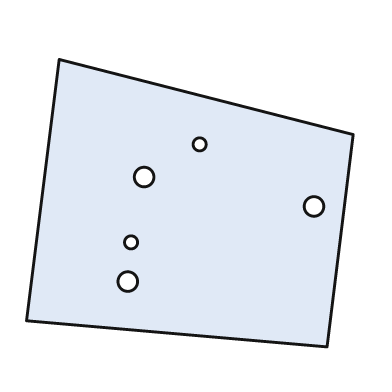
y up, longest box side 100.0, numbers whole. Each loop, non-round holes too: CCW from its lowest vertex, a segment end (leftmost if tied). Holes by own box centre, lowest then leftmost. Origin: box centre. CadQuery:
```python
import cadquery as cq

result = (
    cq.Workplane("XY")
    .moveTo(42.0, -44.0)
    .lineTo(50.0, 21.0)
    .lineTo(-40.0, 44.0)
    .lineTo(-50.0, -36.0)
    .close()
    .moveTo(-19.0, -24.0)
    .circle(3.0)
    .moveTo(-18.0, -12.0)
    .circle(2.0)
    .moveTo(38.0, -1.0)
    .circle(3.0)
    .moveTo(-14.0, 8.0)
    .circle(3.0)
    .moveTo(3.0, 18.0)
    .circle(2.0)
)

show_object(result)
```